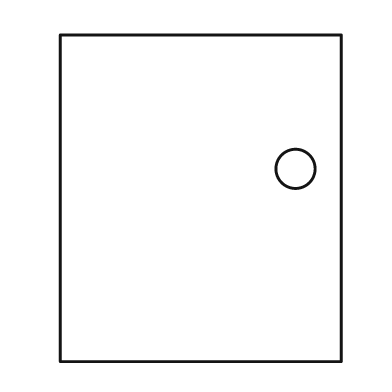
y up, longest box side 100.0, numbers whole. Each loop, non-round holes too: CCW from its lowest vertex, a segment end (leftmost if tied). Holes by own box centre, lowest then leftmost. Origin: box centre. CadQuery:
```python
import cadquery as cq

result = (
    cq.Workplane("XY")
    .moveTo(-43.0, -50.0)
    .lineTo(43.0, -50.0)
    .lineTo(43.0, 50.0)
    .lineTo(-43.0, 50.0)
    .close()
    .moveTo(29.0, 9.0)
    .circle(6.0)
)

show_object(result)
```